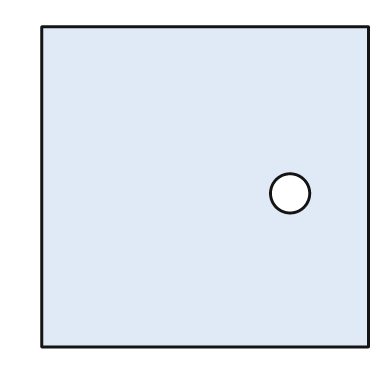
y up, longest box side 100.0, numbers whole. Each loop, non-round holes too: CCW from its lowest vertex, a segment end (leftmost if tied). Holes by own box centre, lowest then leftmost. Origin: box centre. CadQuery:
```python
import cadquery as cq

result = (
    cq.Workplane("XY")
    .moveTo(-50.0, -49.0)
    .lineTo(50.0, -49.0)
    .lineTo(50.0, 49.0)
    .lineTo(-50.0, 49.0)
    .close()
    .moveTo(26.0, -2.0)
    .circle(6.0)
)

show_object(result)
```